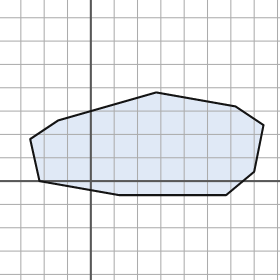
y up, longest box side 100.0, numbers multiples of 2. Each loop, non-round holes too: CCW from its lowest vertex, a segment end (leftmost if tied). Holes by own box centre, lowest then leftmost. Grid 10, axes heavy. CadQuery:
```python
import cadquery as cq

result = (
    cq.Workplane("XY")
    .moveTo(12.0, -6.0)
    .lineTo(58.0, -6.0)
    .lineTo(70.0, 4.0)
    .lineTo(74.0, 24.0)
    .lineTo(62.0, 32.0)
    .lineTo(28.0, 38.0)
    .lineTo(-14.0, 26.0)
    .lineTo(-26.0, 18.0)
    .lineTo(-22.0, 0.0)
    .close()
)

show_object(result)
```